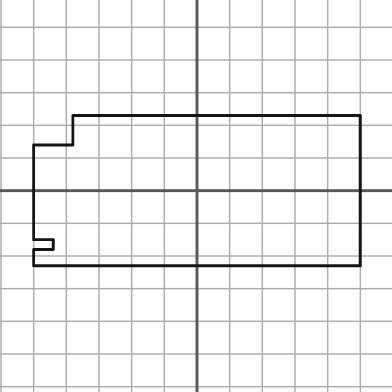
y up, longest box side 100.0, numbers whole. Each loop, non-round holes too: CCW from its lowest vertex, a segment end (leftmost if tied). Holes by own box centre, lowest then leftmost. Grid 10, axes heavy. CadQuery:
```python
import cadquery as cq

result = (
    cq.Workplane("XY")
    .moveTo(-50.0, -23.0)
    .lineTo(50.0, -23.0)
    .lineTo(50.0, 23.0)
    .lineTo(-38.0, 23.0)
    .lineTo(-38.0, 14.0)
    .lineTo(-50.0, 14.0)
    .lineTo(-50.0, -15.0)
    .lineTo(-44.0, -15.0)
    .lineTo(-44.0, -18.0)
    .lineTo(-50.0, -18.0)
    .close()
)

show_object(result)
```